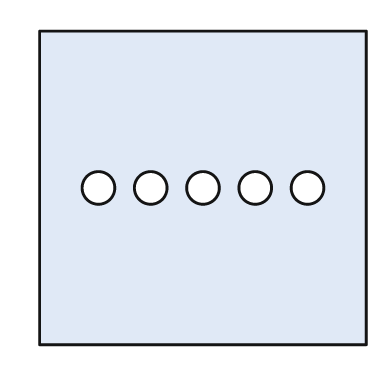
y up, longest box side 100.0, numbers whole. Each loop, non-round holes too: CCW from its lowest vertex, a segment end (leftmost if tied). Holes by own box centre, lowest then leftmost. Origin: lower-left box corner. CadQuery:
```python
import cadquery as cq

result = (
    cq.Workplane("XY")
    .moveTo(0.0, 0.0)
    .lineTo(100.0, 0.0)
    .lineTo(100.0, 96.0)
    .lineTo(0.0, 96.0)
    .close()
    .moveTo(18.0, 48.0)
    .circle(5.0)
    .moveTo(34.0, 48.0)
    .circle(5.0)
    .moveTo(50.0, 48.0)
    .circle(5.0)
    .moveTo(66.0, 48.0)
    .circle(5.0)
    .moveTo(82.0, 48.0)
    .circle(5.0)
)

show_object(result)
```